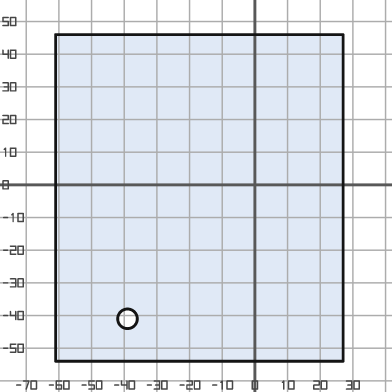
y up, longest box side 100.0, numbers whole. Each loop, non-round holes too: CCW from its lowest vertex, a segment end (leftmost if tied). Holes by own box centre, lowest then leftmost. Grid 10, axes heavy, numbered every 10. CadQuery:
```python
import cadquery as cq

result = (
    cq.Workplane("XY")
    .moveTo(-61.0, -54.0)
    .lineTo(27.0, -54.0)
    .lineTo(27.0, 46.0)
    .lineTo(-61.0, 46.0)
    .close()
    .moveTo(-39.0, -41.0)
    .circle(3.0)
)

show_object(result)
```